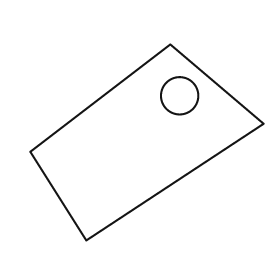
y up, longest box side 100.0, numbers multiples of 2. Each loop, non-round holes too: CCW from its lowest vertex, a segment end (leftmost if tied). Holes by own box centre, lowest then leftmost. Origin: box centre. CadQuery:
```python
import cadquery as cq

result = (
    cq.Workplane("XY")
    .moveTo(-26.0, -42.0)
    .lineTo(50.0, 8.0)
    .lineTo(10.0, 42.0)
    .lineTo(-50.0, -4.0)
    .close()
    .moveTo(14.0, 20.0)
    .circle(8.0)
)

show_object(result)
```